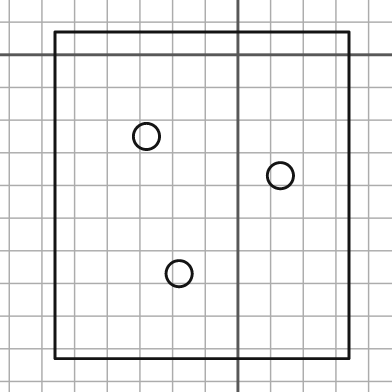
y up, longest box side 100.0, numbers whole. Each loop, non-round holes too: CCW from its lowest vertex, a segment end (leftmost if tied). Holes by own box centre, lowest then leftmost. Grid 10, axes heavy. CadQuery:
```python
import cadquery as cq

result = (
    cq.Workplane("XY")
    .moveTo(-56.0, -93.0)
    .lineTo(34.0, -93.0)
    .lineTo(34.0, 7.0)
    .lineTo(-56.0, 7.0)
    .close()
    .moveTo(-18.0, -67.0)
    .circle(4.0)
    .moveTo(13.0, -37.0)
    .circle(4.0)
    .moveTo(-28.0, -25.0)
    .circle(4.0)
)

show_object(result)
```